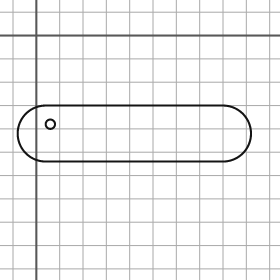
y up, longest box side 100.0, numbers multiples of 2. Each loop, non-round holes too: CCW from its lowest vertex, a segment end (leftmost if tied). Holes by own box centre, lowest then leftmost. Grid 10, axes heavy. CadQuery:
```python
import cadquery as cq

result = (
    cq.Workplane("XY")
    .moveTo(4.0, -54.0)
    .lineTo(80.0, -54.0)
    .threePointArc((92.0, -42.0), (80.0, -30.0))
    .lineTo(4.0, -30.0)
    .threePointArc((-8.0, -42.0), (4.0, -54.0))
    .close()
    .moveTo(6.0, -38.0)
    .circle(2.0)
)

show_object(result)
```